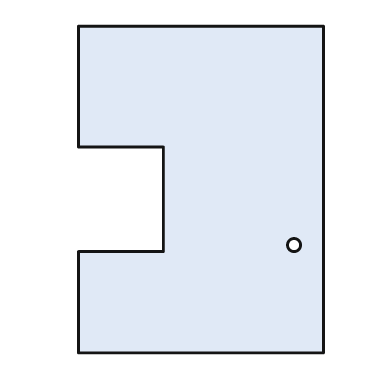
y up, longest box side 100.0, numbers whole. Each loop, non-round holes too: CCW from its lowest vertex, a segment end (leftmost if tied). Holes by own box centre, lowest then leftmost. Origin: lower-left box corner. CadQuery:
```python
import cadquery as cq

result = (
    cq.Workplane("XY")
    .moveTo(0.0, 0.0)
    .lineTo(75.0, 0.0)
    .lineTo(75.0, 100.0)
    .lineTo(0.0, 100.0)
    .lineTo(0.0, 63.0)
    .lineTo(26.0, 63.0)
    .lineTo(26.0, 31.0)
    .lineTo(0.0, 31.0)
    .close()
    .moveTo(66.0, 33.0)
    .circle(2.0)
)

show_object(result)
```